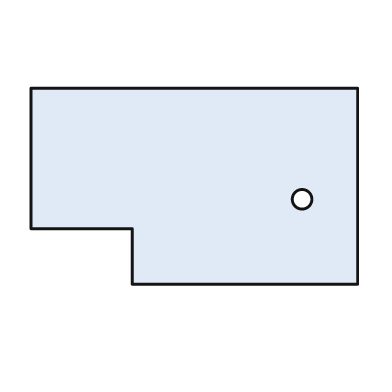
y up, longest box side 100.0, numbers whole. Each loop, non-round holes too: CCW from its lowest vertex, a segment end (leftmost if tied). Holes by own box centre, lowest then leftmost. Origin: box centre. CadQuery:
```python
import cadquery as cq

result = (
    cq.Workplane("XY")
    .moveTo(-19.0, -30.0)
    .lineTo(50.0, -30.0)
    .lineTo(50.0, 30.0)
    .lineTo(-50.0, 30.0)
    .lineTo(-50.0, -13.0)
    .lineTo(-19.0, -13.0)
    .close()
    .moveTo(33.0, -4.0)
    .circle(3.0)
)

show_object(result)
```